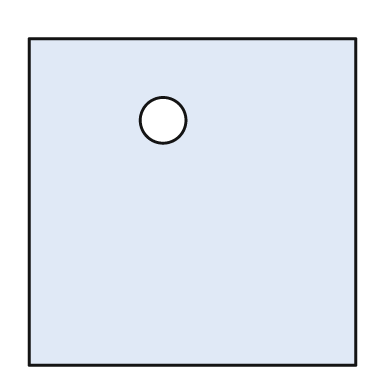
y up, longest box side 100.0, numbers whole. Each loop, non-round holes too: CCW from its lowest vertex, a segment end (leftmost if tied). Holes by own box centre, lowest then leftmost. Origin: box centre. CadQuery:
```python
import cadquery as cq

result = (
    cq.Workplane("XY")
    .moveTo(-50.0, -50.0)
    .lineTo(50.0, -50.0)
    .lineTo(50.0, 50.0)
    .lineTo(-50.0, 50.0)
    .close()
    .moveTo(-9.0, 25.0)
    .circle(7.0)
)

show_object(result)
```